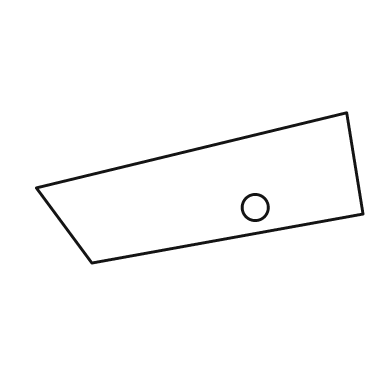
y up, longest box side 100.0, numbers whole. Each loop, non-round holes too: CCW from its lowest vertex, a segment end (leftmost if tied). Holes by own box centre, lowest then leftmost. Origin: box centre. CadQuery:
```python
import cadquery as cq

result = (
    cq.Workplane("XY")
    .moveTo(-33.0, -23.0)
    .lineTo(50.0, -8.0)
    .lineTo(45.0, 23.0)
    .lineTo(-50.0, 0.0)
    .close()
    .moveTo(17.0, -6.0)
    .circle(4.0)
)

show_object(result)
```